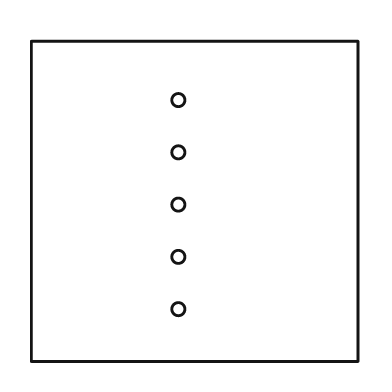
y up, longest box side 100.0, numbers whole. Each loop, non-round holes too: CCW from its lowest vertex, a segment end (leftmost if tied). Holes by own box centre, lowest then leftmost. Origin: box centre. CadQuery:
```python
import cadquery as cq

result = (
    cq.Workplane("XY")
    .moveTo(-50.0, -49.0)
    .lineTo(50.0, -49.0)
    .lineTo(50.0, 49.0)
    .lineTo(-50.0, 49.0)
    .close()
    .moveTo(-5.0, -33.0)
    .circle(2.0)
    .moveTo(-5.0, -17.0)
    .circle(2.0)
    .moveTo(-5.0, -1.0)
    .circle(2.0)
    .moveTo(-5.0, 15.0)
    .circle(2.0)
    .moveTo(-5.0, 31.0)
    .circle(2.0)
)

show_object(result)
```